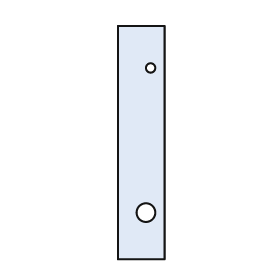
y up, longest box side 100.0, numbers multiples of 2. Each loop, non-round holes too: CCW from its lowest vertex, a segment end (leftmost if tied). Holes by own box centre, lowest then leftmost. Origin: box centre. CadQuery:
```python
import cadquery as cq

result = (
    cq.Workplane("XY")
    .moveTo(-10.0, -50.0)
    .lineTo(10.0, -50.0)
    .lineTo(10.0, 50.0)
    .lineTo(-10.0, 50.0)
    .close()
    .moveTo(2.0, -30.0)
    .circle(4.0)
    .moveTo(4.0, 32.0)
    .circle(2.0)
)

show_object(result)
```